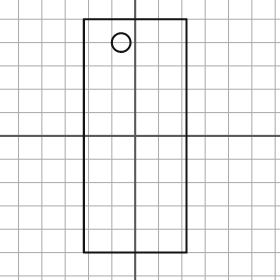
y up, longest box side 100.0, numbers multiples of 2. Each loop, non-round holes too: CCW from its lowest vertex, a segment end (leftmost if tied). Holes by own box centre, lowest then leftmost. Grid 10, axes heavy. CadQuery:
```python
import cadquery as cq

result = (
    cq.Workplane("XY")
    .moveTo(-22.0, -50.0)
    .lineTo(22.0, -50.0)
    .lineTo(22.0, 50.0)
    .lineTo(-22.0, 50.0)
    .close()
    .moveTo(-6.0, 40.0)
    .circle(4.0)
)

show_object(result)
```